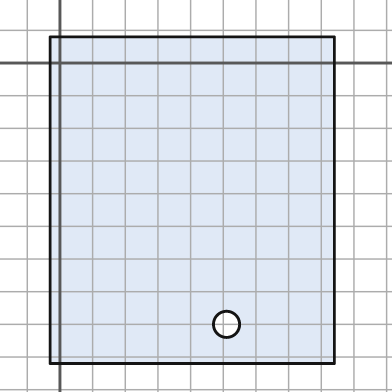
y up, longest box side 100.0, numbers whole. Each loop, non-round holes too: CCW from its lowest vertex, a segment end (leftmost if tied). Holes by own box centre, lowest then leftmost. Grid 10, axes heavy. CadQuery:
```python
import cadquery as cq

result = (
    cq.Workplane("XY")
    .moveTo(-3.0, -92.0)
    .lineTo(84.0, -92.0)
    .lineTo(84.0, 8.0)
    .lineTo(-3.0, 8.0)
    .close()
    .moveTo(51.0, -80.0)
    .circle(4.0)
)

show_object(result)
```